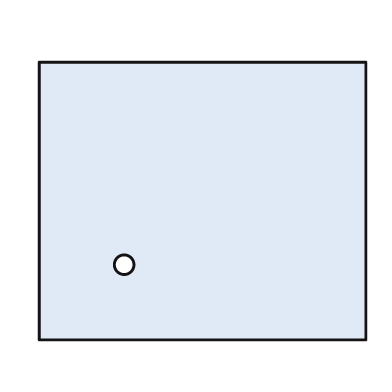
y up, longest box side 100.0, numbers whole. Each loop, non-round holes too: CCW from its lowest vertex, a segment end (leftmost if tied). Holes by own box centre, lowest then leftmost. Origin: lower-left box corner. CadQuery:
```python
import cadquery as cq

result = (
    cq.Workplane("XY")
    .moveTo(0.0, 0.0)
    .lineTo(100.0, 0.0)
    .lineTo(100.0, 85.0)
    .lineTo(0.0, 85.0)
    .close()
    .moveTo(26.0, 23.0)
    .circle(3.0)
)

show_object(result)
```